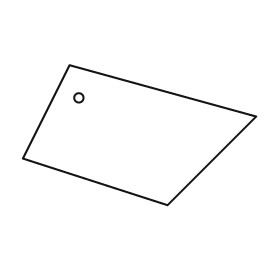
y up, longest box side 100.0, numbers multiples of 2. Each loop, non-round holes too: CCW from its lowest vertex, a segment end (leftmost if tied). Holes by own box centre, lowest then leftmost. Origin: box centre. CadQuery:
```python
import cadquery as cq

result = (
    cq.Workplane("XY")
    .moveTo(12.0, -30.0)
    .lineTo(50.0, 8.0)
    .lineTo(-30.0, 30.0)
    .lineTo(-50.0, -10.0)
    .close()
    .moveTo(-26.0, 16.0)
    .circle(2.0)
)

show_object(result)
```